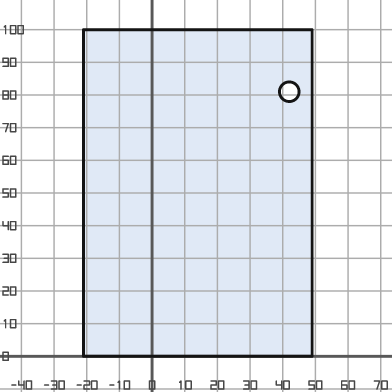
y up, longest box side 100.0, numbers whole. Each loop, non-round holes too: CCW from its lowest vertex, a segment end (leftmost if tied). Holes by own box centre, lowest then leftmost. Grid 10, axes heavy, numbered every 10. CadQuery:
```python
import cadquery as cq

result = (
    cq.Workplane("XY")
    .moveTo(-21.0, 0.0)
    .lineTo(49.0, 0.0)
    .lineTo(49.0, 100.0)
    .lineTo(-21.0, 100.0)
    .close()
    .moveTo(42.0, 81.0)
    .circle(3.0)
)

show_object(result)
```